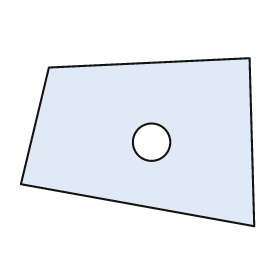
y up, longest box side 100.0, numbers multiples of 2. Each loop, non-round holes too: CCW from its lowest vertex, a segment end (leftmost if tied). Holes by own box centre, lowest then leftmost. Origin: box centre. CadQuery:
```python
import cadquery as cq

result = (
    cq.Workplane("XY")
    .moveTo(50.0, -36.0)
    .lineTo(48.0, 36.0)
    .lineTo(-38.0, 32.0)
    .lineTo(-50.0, -18.0)
    .close()
    .moveTo(6.0, 0.0)
    .circle(8.0)
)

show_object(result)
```